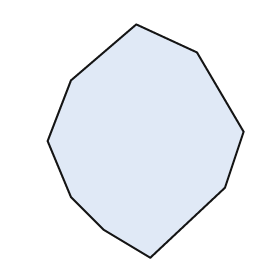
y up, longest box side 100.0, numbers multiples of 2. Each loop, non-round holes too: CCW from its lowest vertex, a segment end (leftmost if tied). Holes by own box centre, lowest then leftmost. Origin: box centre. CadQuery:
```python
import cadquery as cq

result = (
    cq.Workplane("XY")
    .moveTo(2.0, -50.0)
    .lineTo(34.0, -20.0)
    .lineTo(42.0, 4.0)
    .lineTo(22.0, 38.0)
    .lineTo(-4.0, 50.0)
    .lineTo(-32.0, 26.0)
    .lineTo(-42.0, 0.0)
    .lineTo(-32.0, -24.0)
    .lineTo(-18.0, -38.0)
    .close()
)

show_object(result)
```